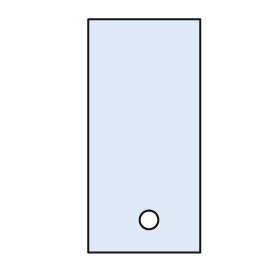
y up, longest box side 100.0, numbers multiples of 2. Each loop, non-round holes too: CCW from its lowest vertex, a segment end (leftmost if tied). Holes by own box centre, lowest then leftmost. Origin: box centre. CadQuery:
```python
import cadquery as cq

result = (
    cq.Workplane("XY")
    .moveTo(-24.0, -50.0)
    .lineTo(24.0, -50.0)
    .lineTo(24.0, 50.0)
    .lineTo(-24.0, 50.0)
    .close()
    .moveTo(2.0, -36.0)
    .circle(4.0)
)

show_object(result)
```